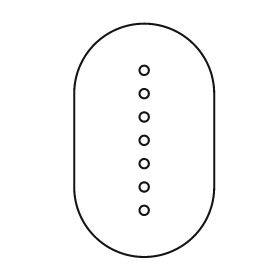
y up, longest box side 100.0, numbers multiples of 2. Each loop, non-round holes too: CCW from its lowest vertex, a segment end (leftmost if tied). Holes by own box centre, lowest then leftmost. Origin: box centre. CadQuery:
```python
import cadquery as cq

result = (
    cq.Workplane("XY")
    .moveTo(-30.0, -20.0)
    .threePointArc((0.0, -50.0), (30.0, -20.0))
    .lineTo(30.0, 20.0)
    .threePointArc((0.0, 50.0), (-30.0, 20.0))
    .close()
    .moveTo(0.0, -30.0)
    .circle(2.0)
    .moveTo(0.0, -20.0)
    .circle(2.0)
    .moveTo(0.0, -10.0)
    .circle(2.0)
    .moveTo(0.0, 0.0)
    .circle(2.0)
    .moveTo(0.0, 10.0)
    .circle(2.0)
    .moveTo(0.0, 20.0)
    .circle(2.0)
    .moveTo(0.0, 30.0)
    .circle(2.0)
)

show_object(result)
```